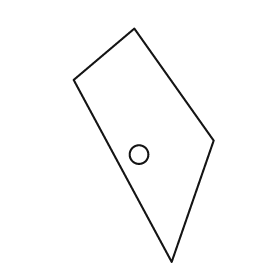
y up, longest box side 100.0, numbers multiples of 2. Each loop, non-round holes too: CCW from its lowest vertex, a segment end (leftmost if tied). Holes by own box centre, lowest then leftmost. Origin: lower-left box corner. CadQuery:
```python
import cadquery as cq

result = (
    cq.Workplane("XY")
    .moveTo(42.0, 0.0)
    .lineTo(60.0, 52.0)
    .lineTo(26.0, 100.0)
    .lineTo(0.0, 78.0)
    .close()
    .moveTo(28.0, 46.0)
    .circle(4.0)
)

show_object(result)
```